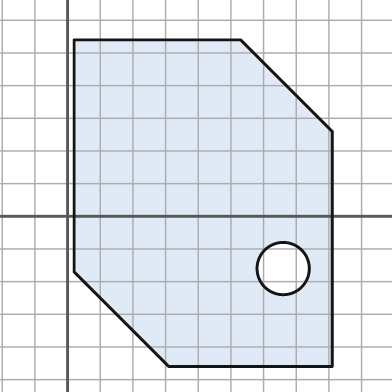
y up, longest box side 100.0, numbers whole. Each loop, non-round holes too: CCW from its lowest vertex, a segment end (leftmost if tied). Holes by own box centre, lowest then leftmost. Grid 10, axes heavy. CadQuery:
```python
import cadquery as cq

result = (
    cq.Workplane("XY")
    .moveTo(31.0, -46.0)
    .lineTo(81.0, -46.0)
    .lineTo(81.0, 26.0)
    .lineTo(53.0, 54.0)
    .lineTo(2.0, 54.0)
    .lineTo(2.0, -17.0)
    .close()
    .moveTo(66.0, -16.0)
    .circle(8.0)
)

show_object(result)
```